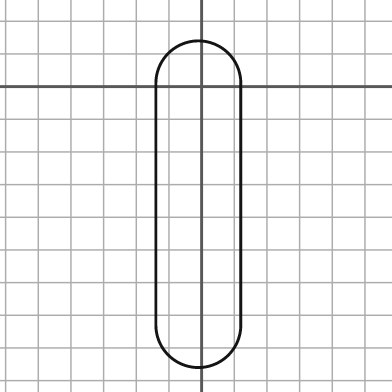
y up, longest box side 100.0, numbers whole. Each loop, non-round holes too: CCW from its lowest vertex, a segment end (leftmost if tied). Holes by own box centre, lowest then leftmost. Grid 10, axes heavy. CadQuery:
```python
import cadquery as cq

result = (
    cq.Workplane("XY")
    .moveTo(-14.0, -73.0)
    .threePointArc((-1.0, -86.0), (12.0, -73.0))
    .lineTo(12.0, 1.0)
    .threePointArc((-1.0, 14.0), (-14.0, 1.0))
    .close()
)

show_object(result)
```